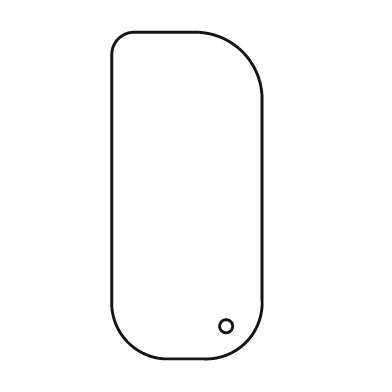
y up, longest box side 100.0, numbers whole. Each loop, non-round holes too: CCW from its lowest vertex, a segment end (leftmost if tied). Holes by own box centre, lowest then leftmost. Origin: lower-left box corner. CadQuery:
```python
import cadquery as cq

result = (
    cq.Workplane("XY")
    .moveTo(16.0, 0.0)
    .lineTo(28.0, 0.0)
    .threePointArc((41.0, 5.0), (46.0, 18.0))
    .lineTo(46.0, 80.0)
    .threePointArc((40.0, 94.0), (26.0, 100.0))
    .lineTo(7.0, 100.0)
    .threePointArc((2.0, 98.0), (0.0, 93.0))
    .lineTo(0.0, 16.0)
    .threePointArc((5.0, 5.0), (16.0, 0.0))
    .close()
    .moveTo(35.0, 10.0)
    .circle(2.0)
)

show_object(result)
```